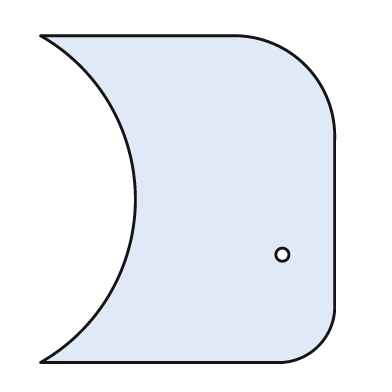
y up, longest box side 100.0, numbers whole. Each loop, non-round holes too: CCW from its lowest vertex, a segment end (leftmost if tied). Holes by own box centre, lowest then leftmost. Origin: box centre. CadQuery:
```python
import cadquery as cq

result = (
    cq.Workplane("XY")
    .moveTo(-45.0, -50.0)
    .lineTo(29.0, -50.0)
    .threePointArc((40.0, -45.0), (45.0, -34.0))
    .lineTo(45.0, 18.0)
    .threePointArc((36.0, 41.0), (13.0, 50.0))
    .lineTo(-45.0, 50.0)
    .threePointArc((-16.0, 0.0), (-45.0, -50.0))
    .close()
    .moveTo(29.0, -17.0)
    .circle(2.0)
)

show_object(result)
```